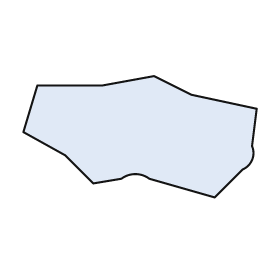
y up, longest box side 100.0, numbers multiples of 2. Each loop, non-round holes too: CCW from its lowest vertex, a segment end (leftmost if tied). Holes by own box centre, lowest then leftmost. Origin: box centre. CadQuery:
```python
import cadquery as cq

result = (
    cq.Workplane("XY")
    .moveTo(32.0, -26.0)
    .lineTo(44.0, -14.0)
    .threePointArc((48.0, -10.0), (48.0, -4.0))
    .lineTo(50.0, 12.0)
    .lineTo(22.0, 18.0)
    .lineTo(6.0, 26.0)
    .lineTo(-16.0, 22.0)
    .lineTo(-44.0, 22.0)
    .lineTo(-50.0, 2.0)
    .lineTo(-32.0, -8.0)
    .lineTo(-20.0, -20.0)
    .lineTo(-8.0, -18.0)
    .threePointArc((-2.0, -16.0), (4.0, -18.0))
    .close()
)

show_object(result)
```